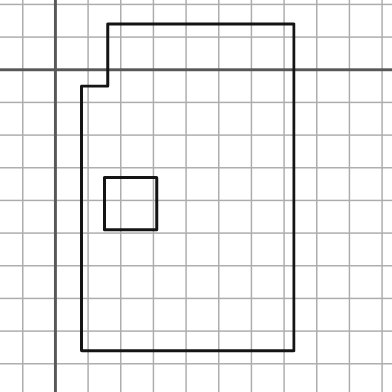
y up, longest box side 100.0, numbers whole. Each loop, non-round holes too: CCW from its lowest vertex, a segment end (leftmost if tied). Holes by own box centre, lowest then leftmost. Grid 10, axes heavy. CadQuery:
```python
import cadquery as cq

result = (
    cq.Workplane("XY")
    .moveTo(8.0, -86.0)
    .lineTo(73.0, -86.0)
    .lineTo(73.0, 14.0)
    .lineTo(16.0, 14.0)
    .lineTo(16.0, -5.0)
    .lineTo(8.0, -5.0)
    .close()
    .moveTo(15.0, -49.0)
    .lineTo(31.0, -49.0)
    .lineTo(31.0, -33.0)
    .lineTo(15.0, -33.0)
    .close()
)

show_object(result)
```